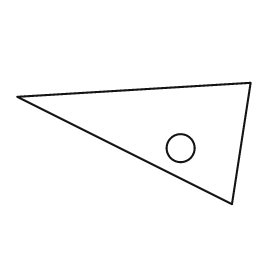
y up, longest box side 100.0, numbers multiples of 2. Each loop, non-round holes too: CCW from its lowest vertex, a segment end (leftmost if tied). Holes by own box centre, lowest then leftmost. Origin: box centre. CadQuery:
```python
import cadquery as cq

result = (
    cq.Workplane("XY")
    .moveTo(42.0, -26.0)
    .lineTo(50.0, 26.0)
    .lineTo(-50.0, 20.0)
    .close()
    .moveTo(20.0, -2.0)
    .circle(6.0)
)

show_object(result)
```